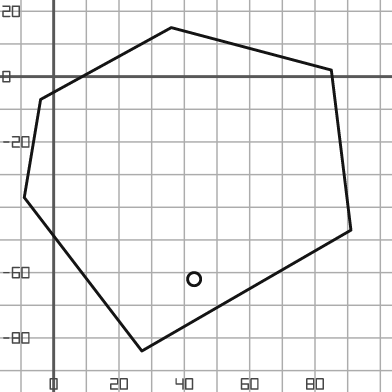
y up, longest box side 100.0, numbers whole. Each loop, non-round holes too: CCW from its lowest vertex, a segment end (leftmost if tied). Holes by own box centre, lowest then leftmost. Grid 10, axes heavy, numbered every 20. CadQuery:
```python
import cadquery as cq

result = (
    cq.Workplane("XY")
    .moveTo(27.0, -84.0)
    .lineTo(91.0, -47.0)
    .lineTo(85.0, 2.0)
    .lineTo(36.0, 15.0)
    .lineTo(-4.0, -7.0)
    .lineTo(-9.0, -37.0)
    .close()
    .moveTo(43.0, -62.0)
    .circle(2.0)
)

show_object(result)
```